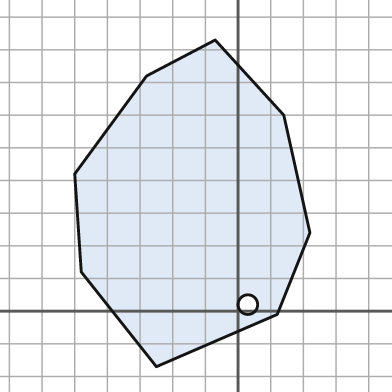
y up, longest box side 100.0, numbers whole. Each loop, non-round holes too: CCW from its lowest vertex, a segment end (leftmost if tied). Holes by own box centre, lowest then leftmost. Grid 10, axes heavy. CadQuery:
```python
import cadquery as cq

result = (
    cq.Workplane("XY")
    .moveTo(-25.0, -17.0)
    .lineTo(12.0, -1.0)
    .lineTo(22.0, 24.0)
    .lineTo(14.0, 60.0)
    .lineTo(-7.0, 83.0)
    .lineTo(-28.0, 72.0)
    .lineTo(-50.0, 42.0)
    .lineTo(-48.0, 12.0)
    .close()
    .moveTo(3.0, 2.0)
    .circle(3.0)
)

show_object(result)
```